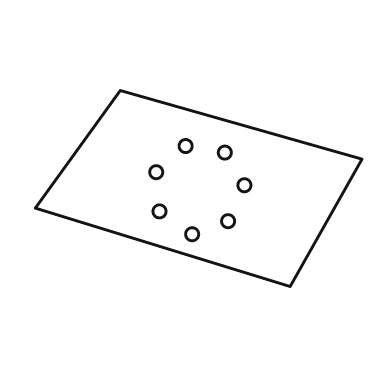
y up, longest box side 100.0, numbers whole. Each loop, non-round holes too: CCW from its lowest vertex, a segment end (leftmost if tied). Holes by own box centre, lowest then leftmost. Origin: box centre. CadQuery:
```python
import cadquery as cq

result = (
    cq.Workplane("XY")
    .moveTo(28.0, -30.0)
    .lineTo(50.0, 9.0)
    .lineTo(-24.0, 30.0)
    .lineTo(-50.0, -6.0)
    .close()
    .moveTo(-2.0, -14.0)
    .circle(2.0)
    .moveTo(9.0, -10.0)
    .circle(2.0)
    .moveTo(-12.0, -7.0)
    .circle(2.0)
    .moveTo(14.0, 1.0)
    .circle(2.0)
    .moveTo(-13.0, 5.0)
    .circle(2.0)
    .moveTo(8.0, 11.0)
    .circle(2.0)
    .moveTo(-4.0, 13.0)
    .circle(2.0)
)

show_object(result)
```